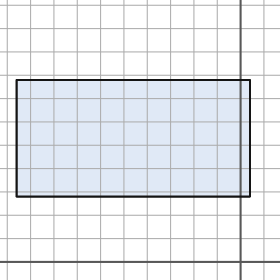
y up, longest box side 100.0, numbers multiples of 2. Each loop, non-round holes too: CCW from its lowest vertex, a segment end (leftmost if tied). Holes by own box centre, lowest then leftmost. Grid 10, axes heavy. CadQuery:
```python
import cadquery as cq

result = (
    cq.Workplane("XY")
    .moveTo(-96.0, 28.0)
    .lineTo(4.0, 28.0)
    .lineTo(4.0, 78.0)
    .lineTo(-96.0, 78.0)
    .close()
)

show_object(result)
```